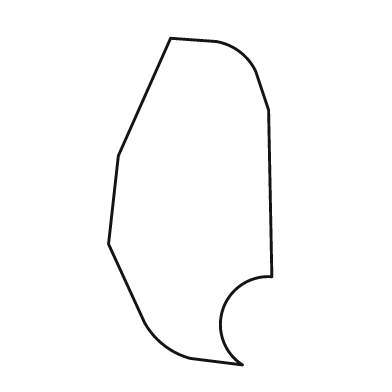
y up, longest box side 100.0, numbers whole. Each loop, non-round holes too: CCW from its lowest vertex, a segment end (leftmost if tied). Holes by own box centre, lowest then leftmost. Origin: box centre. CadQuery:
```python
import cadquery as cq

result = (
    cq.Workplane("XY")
    .moveTo(16.0, -50.0)
    .threePointArc((10.0, -33.0), (25.0, -23.0))
    .lineTo(24.0, 28.0)
    .lineTo(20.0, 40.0)
    .threePointArc((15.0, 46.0), (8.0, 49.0))
    .lineTo(-6.0, 50.0)
    .lineTo(-22.0, 14.0)
    .lineTo(-25.0, -13.0)
    .lineTo(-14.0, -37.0)
    .threePointArc((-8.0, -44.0), (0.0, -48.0))
    .close()
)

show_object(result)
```